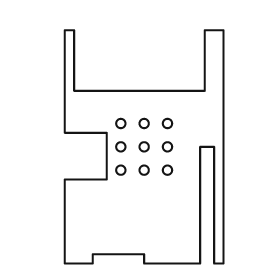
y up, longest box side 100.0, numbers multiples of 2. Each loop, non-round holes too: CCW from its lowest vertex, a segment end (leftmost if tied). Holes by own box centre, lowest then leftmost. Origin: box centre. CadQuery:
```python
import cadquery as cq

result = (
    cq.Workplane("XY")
    .moveTo(-34.0, -50.0)
    .lineTo(-22.0, -50.0)
    .lineTo(-22.0, -46.0)
    .lineTo(0.0, -46.0)
    .lineTo(0.0, -50.0)
    .lineTo(24.0, -50.0)
    .lineTo(24.0, 0.0)
    .lineTo(30.0, 0.0)
    .lineTo(30.0, -50.0)
    .lineTo(34.0, -50.0)
    .lineTo(34.0, 50.0)
    .lineTo(26.0, 50.0)
    .lineTo(26.0, 24.0)
    .lineTo(-30.0, 24.0)
    .lineTo(-30.0, 50.0)
    .lineTo(-34.0, 50.0)
    .lineTo(-34.0, 6.0)
    .lineTo(-16.0, 6.0)
    .lineTo(-16.0, -14.0)
    .lineTo(-34.0, -14.0)
    .close()
    .moveTo(-10.0, -10.0)
    .circle(2.0)
    .moveTo(0.0, -10.0)
    .circle(2.0)
    .moveTo(10.0, -10.0)
    .circle(2.0)
    .moveTo(-10.0, 0.0)
    .circle(2.0)
    .moveTo(0.0, 0.0)
    .circle(2.0)
    .moveTo(10.0, 0.0)
    .circle(2.0)
    .moveTo(-10.0, 10.0)
    .circle(2.0)
    .moveTo(0.0, 10.0)
    .circle(2.0)
    .moveTo(10.0, 10.0)
    .circle(2.0)
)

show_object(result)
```